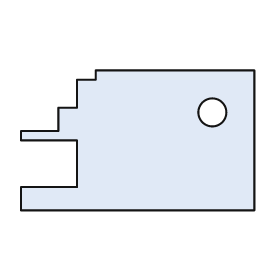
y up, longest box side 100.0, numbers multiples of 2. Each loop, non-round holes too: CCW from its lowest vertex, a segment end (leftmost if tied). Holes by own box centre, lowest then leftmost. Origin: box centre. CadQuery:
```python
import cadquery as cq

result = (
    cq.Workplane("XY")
    .moveTo(-50.0, -30.0)
    .lineTo(50.0, -30.0)
    .lineTo(50.0, 30.0)
    .lineTo(-18.0, 30.0)
    .lineTo(-18.0, 26.0)
    .lineTo(-26.0, 26.0)
    .lineTo(-26.0, 14.0)
    .lineTo(-34.0, 14.0)
    .lineTo(-34.0, 4.0)
    .lineTo(-50.0, 4.0)
    .lineTo(-50.0, 0.0)
    .lineTo(-26.0, 0.0)
    .lineTo(-26.0, -20.0)
    .lineTo(-50.0, -20.0)
    .close()
    .moveTo(32.0, 12.0)
    .circle(6.0)
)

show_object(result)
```